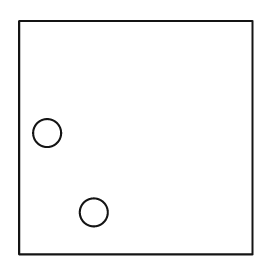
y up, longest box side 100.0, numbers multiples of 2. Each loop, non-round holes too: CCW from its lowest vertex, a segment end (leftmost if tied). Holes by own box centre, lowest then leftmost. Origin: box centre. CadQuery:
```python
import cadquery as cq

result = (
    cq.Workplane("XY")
    .moveTo(-50.0, -50.0)
    .lineTo(50.0, -50.0)
    .lineTo(50.0, 50.0)
    .lineTo(-50.0, 50.0)
    .close()
    .moveTo(-18.0, -32.0)
    .circle(6.0)
    .moveTo(-38.0, 2.0)
    .circle(6.0)
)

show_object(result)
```